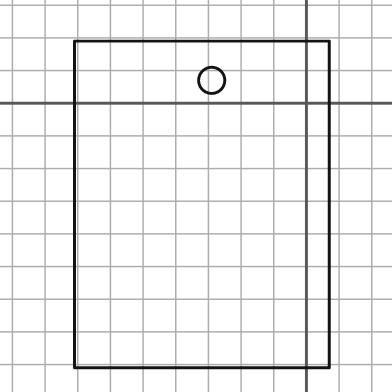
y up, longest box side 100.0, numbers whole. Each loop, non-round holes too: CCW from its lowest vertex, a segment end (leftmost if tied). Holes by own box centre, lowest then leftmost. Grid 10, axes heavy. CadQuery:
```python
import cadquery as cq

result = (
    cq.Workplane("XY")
    .moveTo(-71.0, -81.0)
    .lineTo(7.0, -81.0)
    .lineTo(7.0, 19.0)
    .lineTo(-71.0, 19.0)
    .close()
    .moveTo(-29.0, 7.0)
    .circle(4.0)
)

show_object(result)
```